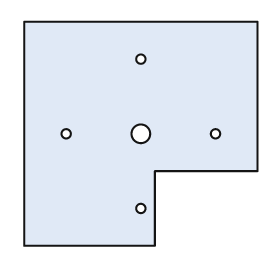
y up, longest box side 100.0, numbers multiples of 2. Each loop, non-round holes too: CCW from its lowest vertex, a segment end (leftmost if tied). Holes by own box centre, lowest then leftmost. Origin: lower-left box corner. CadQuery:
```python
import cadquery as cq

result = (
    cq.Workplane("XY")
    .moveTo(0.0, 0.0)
    .lineTo(56.0, 0.0)
    .lineTo(56.0, 32.0)
    .lineTo(100.0, 32.0)
    .lineTo(100.0, 96.0)
    .lineTo(0.0, 96.0)
    .close()
    .moveTo(50.0, 16.0)
    .circle(2.0)
    .moveTo(18.0, 48.0)
    .circle(2.0)
    .moveTo(50.0, 48.0)
    .circle(4.0)
    .moveTo(82.0, 48.0)
    .circle(2.0)
    .moveTo(50.0, 80.0)
    .circle(2.0)
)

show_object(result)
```